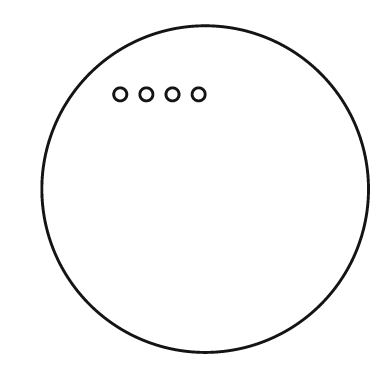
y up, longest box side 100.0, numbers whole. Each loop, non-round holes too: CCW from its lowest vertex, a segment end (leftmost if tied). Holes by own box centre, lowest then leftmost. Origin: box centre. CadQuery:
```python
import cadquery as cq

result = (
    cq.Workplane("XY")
    .moveTo(0.0, 0.0)
    .circle(50.0)
    .moveTo(-26.0, 29.0)
    .circle(2.0)
    .moveTo(-18.0, 29.0)
    .circle(2.0)
    .moveTo(-10.0, 29.0)
    .circle(2.0)
    .moveTo(-2.0, 29.0)
    .circle(2.0)
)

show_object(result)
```